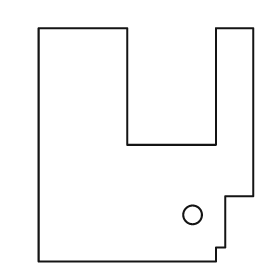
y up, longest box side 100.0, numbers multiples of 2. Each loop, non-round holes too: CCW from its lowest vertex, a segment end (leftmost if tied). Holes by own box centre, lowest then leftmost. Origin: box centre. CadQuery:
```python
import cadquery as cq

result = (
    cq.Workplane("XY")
    .moveTo(-46.0, -50.0)
    .lineTo(30.0, -50.0)
    .lineTo(30.0, -44.0)
    .lineTo(34.0, -44.0)
    .lineTo(34.0, -22.0)
    .lineTo(46.0, -22.0)
    .lineTo(46.0, 50.0)
    .lineTo(30.0, 50.0)
    .lineTo(30.0, 0.0)
    .lineTo(-8.0, 0.0)
    .lineTo(-8.0, 50.0)
    .lineTo(-46.0, 50.0)
    .close()
    .moveTo(20.0, -30.0)
    .circle(4.0)
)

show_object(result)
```